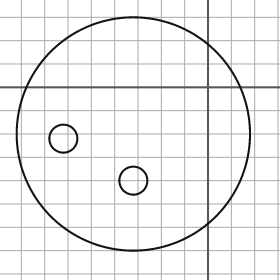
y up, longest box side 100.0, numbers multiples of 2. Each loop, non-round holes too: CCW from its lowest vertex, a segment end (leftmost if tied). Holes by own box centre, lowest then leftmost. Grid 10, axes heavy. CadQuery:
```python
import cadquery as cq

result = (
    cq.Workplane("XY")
    .moveTo(-32.0, -20.0)
    .circle(50.0)
    .moveTo(-32.0, -40.0)
    .circle(6.0)
    .moveTo(-62.0, -22.0)
    .circle(6.0)
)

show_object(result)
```